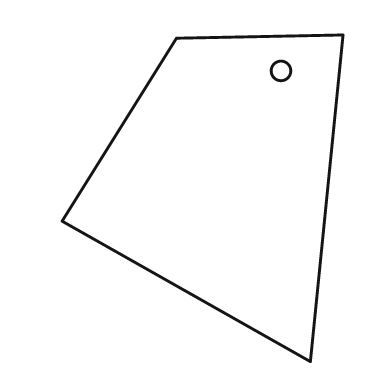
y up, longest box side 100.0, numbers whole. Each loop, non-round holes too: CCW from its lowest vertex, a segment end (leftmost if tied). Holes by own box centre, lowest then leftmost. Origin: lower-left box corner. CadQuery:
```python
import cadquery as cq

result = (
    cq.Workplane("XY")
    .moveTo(76.0, 0.0)
    .lineTo(86.0, 100.0)
    .lineTo(35.0, 99.0)
    .lineTo(0.0, 43.0)
    .close()
    .moveTo(67.0, 89.0)
    .circle(3.0)
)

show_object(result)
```